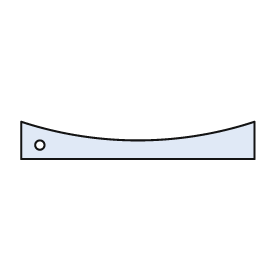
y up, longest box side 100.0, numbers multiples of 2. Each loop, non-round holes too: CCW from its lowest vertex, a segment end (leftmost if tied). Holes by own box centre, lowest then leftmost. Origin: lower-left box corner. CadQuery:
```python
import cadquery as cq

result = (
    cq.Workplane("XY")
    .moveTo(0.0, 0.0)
    .lineTo(100.0, 0.0)
    .lineTo(100.0, 16.0)
    .threePointArc((50.0, 8.0), (0.0, 16.0))
    .close()
    .moveTo(8.0, 6.0)
    .circle(2.0)
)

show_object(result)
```